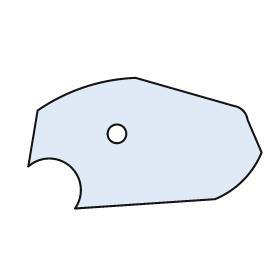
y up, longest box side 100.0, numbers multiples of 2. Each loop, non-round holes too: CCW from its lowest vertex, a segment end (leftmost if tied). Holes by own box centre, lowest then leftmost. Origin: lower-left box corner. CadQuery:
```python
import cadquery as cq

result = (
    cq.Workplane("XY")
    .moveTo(20.0, 0.0)
    .lineTo(80.0, 4.0)
    .threePointArc((92.0, 12.0), (100.0, 24.0))
    .lineTo(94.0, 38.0)
    .threePointArc((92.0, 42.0), (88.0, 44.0))
    .lineTo(46.0, 56.0)
    .threePointArc((24.0, 52.0), (4.0, 42.0))
    .lineTo(0.0, 18.0)
    .threePointArc((18.0, 18.0), (20.0, 0.0))
    .close()
    .moveTo(38.0, 32.0)
    .circle(4.0)
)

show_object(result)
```